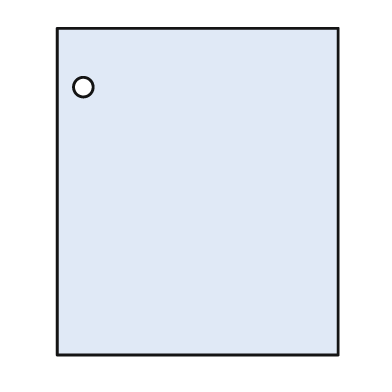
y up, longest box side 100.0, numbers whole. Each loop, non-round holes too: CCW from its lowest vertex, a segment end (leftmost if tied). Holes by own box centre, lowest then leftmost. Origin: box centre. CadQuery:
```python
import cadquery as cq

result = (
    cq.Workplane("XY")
    .moveTo(-43.0, -50.0)
    .lineTo(43.0, -50.0)
    .lineTo(43.0, 50.0)
    .lineTo(-43.0, 50.0)
    .close()
    .moveTo(-35.0, 32.0)
    .circle(3.0)
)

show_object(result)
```